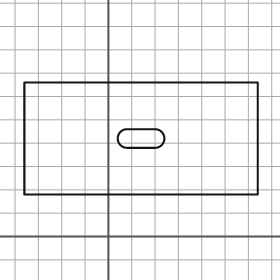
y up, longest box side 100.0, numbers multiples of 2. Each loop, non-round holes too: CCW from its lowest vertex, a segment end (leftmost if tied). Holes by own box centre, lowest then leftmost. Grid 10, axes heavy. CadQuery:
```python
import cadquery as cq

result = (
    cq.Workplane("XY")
    .moveTo(-36.0, 18.0)
    .lineTo(64.0, 18.0)
    .lineTo(64.0, 66.0)
    .lineTo(-36.0, 66.0)
    .close()
    .moveTo(8.0, 38.0)
    .lineTo(20.0, 38.0)
    .threePointArc((24.0, 42.0), (20.0, 46.0))
    .lineTo(8.0, 46.0)
    .threePointArc((4.0, 42.0), (8.0, 38.0))
    .close()
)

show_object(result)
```